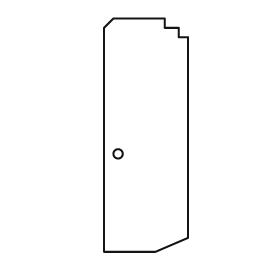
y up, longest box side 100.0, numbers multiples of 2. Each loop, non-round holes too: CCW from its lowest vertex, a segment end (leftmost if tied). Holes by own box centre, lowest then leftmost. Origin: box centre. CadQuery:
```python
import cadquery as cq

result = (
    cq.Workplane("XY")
    .moveTo(-18.0, -50.0)
    .lineTo(4.0, -50.0)
    .lineTo(18.0, -44.0)
    .lineTo(18.0, 42.0)
    .lineTo(14.0, 42.0)
    .lineTo(14.0, 46.0)
    .lineTo(8.0, 46.0)
    .lineTo(8.0, 50.0)
    .lineTo(-14.0, 50.0)
    .lineTo(-18.0, 46.0)
    .close()
    .moveTo(-12.0, -8.0)
    .circle(2.0)
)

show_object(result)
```